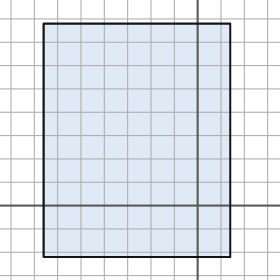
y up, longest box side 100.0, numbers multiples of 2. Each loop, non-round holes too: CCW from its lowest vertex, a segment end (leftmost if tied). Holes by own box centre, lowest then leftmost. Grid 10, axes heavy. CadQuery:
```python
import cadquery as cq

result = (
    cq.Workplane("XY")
    .moveTo(-66.0, -22.0)
    .lineTo(14.0, -22.0)
    .lineTo(14.0, 78.0)
    .lineTo(-66.0, 78.0)
    .close()
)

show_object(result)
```